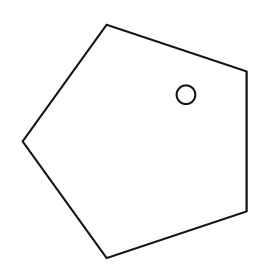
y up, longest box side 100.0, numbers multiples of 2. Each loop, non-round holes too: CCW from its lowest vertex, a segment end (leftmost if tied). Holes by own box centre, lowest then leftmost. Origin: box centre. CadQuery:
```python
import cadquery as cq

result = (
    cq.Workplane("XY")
    .moveTo(-12.0, -50.0)
    .lineTo(48.0, -30.0)
    .lineTo(48.0, 30.0)
    .lineTo(-12.0, 50.0)
    .lineTo(-48.0, 0.0)
    .close()
    .moveTo(22.0, 20.0)
    .circle(4.0)
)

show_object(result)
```